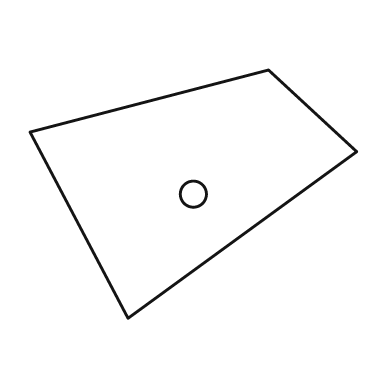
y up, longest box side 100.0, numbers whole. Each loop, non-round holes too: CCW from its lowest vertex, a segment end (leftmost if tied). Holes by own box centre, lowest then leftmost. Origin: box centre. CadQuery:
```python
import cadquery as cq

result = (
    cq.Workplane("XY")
    .moveTo(-20.0, -38.0)
    .lineTo(50.0, 13.0)
    .lineTo(23.0, 38.0)
    .lineTo(-50.0, 19.0)
    .close()
    .moveTo(0.0, 0.0)
    .circle(4.0)
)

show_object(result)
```